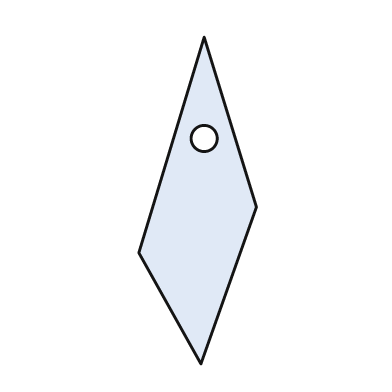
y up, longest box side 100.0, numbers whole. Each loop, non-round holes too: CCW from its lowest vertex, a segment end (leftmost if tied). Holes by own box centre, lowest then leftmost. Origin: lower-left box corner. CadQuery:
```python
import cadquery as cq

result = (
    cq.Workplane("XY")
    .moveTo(19.0, 0.0)
    .lineTo(36.0, 48.0)
    .lineTo(20.0, 100.0)
    .lineTo(0.0, 34.0)
    .close()
    .moveTo(20.0, 69.0)
    .circle(4.0)
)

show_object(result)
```